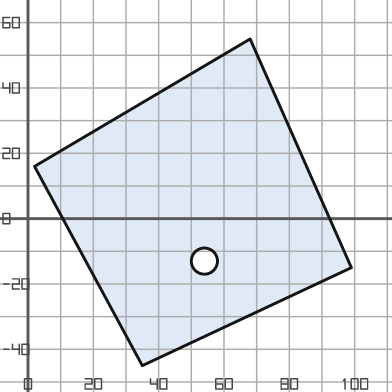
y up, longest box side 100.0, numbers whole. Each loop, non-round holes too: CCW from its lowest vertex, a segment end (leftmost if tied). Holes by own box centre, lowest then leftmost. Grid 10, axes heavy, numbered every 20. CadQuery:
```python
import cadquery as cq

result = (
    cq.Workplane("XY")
    .moveTo(35.0, -45.0)
    .lineTo(99.0, -15.0)
    .lineTo(68.0, 55.0)
    .lineTo(2.0, 16.0)
    .close()
    .moveTo(54.0, -13.0)
    .circle(4.0)
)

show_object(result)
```